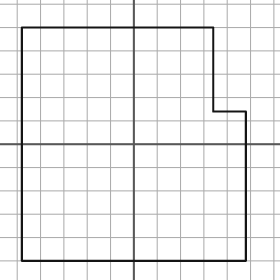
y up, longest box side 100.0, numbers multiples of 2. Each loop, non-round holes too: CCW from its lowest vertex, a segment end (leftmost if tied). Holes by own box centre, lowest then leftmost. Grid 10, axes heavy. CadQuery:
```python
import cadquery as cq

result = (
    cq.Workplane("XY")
    .moveTo(-48.0, -50.0)
    .lineTo(48.0, -50.0)
    .lineTo(48.0, 14.0)
    .lineTo(34.0, 14.0)
    .lineTo(34.0, 50.0)
    .lineTo(-48.0, 50.0)
    .close()
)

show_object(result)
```